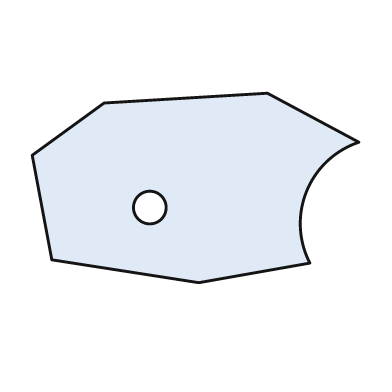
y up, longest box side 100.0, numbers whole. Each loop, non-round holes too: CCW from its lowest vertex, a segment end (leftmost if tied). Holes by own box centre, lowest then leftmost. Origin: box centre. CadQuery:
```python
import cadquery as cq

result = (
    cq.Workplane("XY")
    .moveTo(1.0, -29.0)
    .lineTo(35.0, -23.0)
    .threePointArc((34.0, -1.0), (50.0, 14.0))
    .lineTo(22.0, 29.0)
    .lineTo(-28.0, 26.0)
    .lineTo(-50.0, 10.0)
    .lineTo(-44.0, -22.0)
    .close()
    .moveTo(-14.0, -6.0)
    .circle(5.0)
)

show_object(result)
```